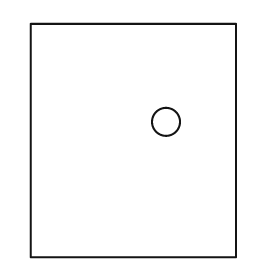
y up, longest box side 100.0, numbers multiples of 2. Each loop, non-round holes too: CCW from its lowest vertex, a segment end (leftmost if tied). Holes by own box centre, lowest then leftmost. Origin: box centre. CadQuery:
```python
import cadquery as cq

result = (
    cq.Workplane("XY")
    .moveTo(-44.0, -50.0)
    .lineTo(44.0, -50.0)
    .lineTo(44.0, 50.0)
    .lineTo(-44.0, 50.0)
    .close()
    .moveTo(14.0, 8.0)
    .circle(6.0)
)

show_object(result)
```